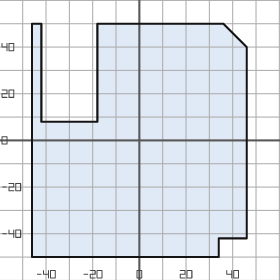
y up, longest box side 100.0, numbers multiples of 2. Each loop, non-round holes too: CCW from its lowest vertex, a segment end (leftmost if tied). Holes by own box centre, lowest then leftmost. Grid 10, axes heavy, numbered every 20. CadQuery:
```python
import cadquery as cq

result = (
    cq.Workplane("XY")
    .moveTo(-46.0, -50.0)
    .lineTo(34.0, -50.0)
    .lineTo(34.0, -42.0)
    .lineTo(46.0, -42.0)
    .lineTo(46.0, 40.0)
    .lineTo(36.0, 50.0)
    .lineTo(-18.0, 50.0)
    .lineTo(-18.0, 8.0)
    .lineTo(-42.0, 8.0)
    .lineTo(-42.0, 50.0)
    .lineTo(-46.0, 50.0)
    .close()
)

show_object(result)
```